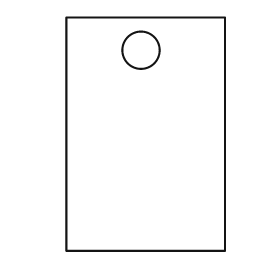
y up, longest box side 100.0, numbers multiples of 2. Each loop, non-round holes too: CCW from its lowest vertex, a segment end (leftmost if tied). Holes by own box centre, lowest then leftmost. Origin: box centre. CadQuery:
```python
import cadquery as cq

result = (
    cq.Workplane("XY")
    .moveTo(-34.0, -50.0)
    .lineTo(34.0, -50.0)
    .lineTo(34.0, 50.0)
    .lineTo(-34.0, 50.0)
    .close()
    .moveTo(-2.0, 36.0)
    .circle(8.0)
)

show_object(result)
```